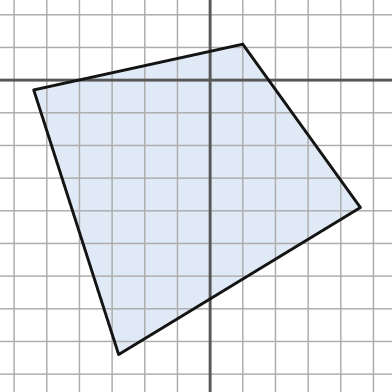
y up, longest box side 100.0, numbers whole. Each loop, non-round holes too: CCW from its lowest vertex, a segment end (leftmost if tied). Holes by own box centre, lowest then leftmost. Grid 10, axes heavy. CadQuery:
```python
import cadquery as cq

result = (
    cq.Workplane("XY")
    .moveTo(-28.0, -84.0)
    .lineTo(46.0, -39.0)
    .lineTo(10.0, 11.0)
    .lineTo(-54.0, -3.0)
    .close()
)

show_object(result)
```